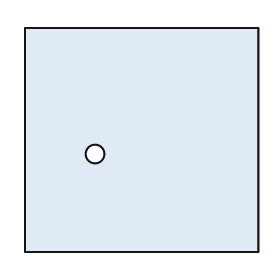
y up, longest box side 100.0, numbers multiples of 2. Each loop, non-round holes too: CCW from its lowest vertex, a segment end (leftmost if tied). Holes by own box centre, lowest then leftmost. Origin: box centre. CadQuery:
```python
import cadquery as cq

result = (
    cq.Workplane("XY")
    .moveTo(-50.0, -48.0)
    .lineTo(50.0, -48.0)
    .lineTo(50.0, 48.0)
    .lineTo(-50.0, 48.0)
    .close()
    .moveTo(-20.0, -6.0)
    .circle(4.0)
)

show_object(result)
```